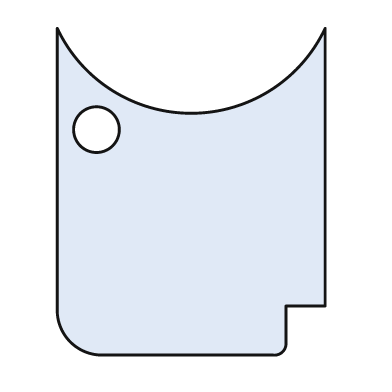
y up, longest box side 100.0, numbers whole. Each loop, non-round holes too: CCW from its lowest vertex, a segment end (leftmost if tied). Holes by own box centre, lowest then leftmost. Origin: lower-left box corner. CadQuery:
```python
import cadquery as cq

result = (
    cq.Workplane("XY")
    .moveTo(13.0, 0.0)
    .lineTo(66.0, 0.0)
    .threePointArc((69.0, 1.0), (70.0, 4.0))
    .lineTo(70.0, 15.0)
    .lineTo(82.0, 15.0)
    .lineTo(82.0, 100.0)
    .threePointArc((41.0, 74.0), (0.0, 100.0))
    .lineTo(0.0, 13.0)
    .threePointArc((4.0, 4.0), (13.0, 0.0))
    .close()
    .moveTo(12.0, 69.0)
    .circle(7.0)
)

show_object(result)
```